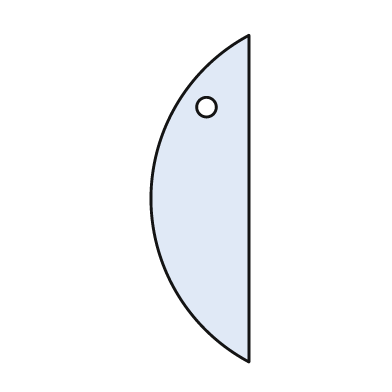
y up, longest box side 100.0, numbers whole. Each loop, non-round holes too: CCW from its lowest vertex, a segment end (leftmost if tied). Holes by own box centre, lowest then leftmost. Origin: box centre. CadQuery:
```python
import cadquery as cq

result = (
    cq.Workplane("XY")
    .moveTo(15.0, -50.0)
    .lineTo(15.0, 50.0)
    .threePointArc((-15.0, 0.0), (15.0, -50.0))
    .close()
    .moveTo(2.0, 28.0)
    .circle(3.0)
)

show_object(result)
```